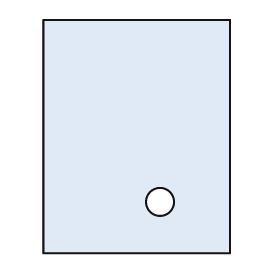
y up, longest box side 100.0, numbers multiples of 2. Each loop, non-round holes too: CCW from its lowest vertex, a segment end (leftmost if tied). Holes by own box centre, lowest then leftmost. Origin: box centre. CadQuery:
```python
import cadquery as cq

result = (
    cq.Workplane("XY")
    .moveTo(-40.0, -50.0)
    .lineTo(40.0, -50.0)
    .lineTo(40.0, 50.0)
    .lineTo(-40.0, 50.0)
    .close()
    .moveTo(10.0, -28.0)
    .circle(6.0)
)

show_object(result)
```